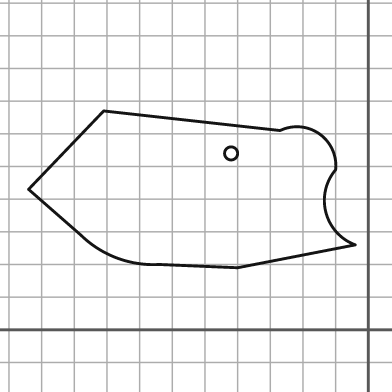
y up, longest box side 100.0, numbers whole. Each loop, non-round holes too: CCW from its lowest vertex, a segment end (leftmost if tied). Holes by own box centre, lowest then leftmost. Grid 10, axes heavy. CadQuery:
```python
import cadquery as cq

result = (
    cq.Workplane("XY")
    .moveTo(-40.0, 19.0)
    .lineTo(-4.0, 26.0)
    .threePointArc((-13.0, 36.0), (-10.0, 49.0))
    .threePointArc((-15.0, 60.0), (-27.0, 61.0))
    .lineTo(-81.0, 67.0)
    .lineTo(-104.0, 43.0)
    .lineTo(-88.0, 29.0)
    .threePointArc((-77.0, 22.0), (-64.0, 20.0))
    .close()
    .moveTo(-42.0, 54.0)
    .circle(2.0)
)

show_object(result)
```